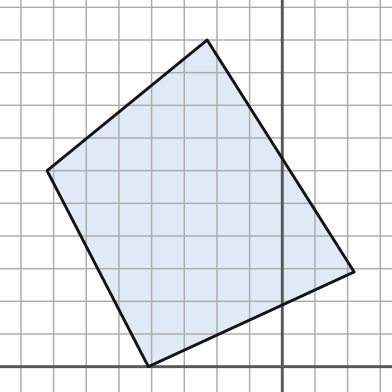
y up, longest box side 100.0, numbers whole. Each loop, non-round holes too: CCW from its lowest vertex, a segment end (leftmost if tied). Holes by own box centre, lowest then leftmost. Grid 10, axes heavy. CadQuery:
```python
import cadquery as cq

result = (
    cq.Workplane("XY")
    .moveTo(-41.0, 0.0)
    .lineTo(22.0, 29.0)
    .lineTo(-23.0, 100.0)
    .lineTo(-72.0, 60.0)
    .close()
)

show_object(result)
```